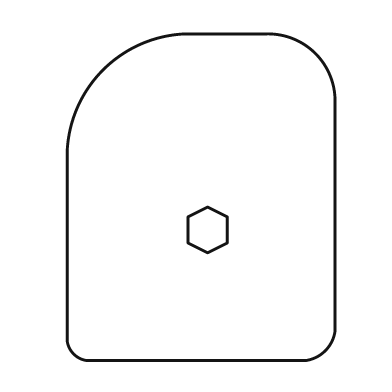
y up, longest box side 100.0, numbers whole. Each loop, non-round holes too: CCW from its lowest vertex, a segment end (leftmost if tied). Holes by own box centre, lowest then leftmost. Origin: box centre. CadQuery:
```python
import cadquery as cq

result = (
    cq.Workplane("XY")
    .moveTo(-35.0, -50.0)
    .lineTo(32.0, -50.0)
    .threePointArc((38.0, -47.0), (41.0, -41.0))
    .lineTo(41.0, 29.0)
    .threePointArc((35.0, 44.0), (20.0, 50.0))
    .lineTo(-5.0, 50.0)
    .threePointArc((-30.0, 39.0), (-41.0, 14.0))
    .lineTo(-41.0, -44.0)
    .threePointArc((-39.0, -48.0), (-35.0, -50.0))
    .close()
    .moveTo(2.0, -17.0)
    .lineTo(8.0, -14.0)
    .lineTo(8.0, -6.0)
    .lineTo(2.0, -3.0)
    .lineTo(-4.0, -6.0)
    .lineTo(-4.0, -14.0)
    .close()
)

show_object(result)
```